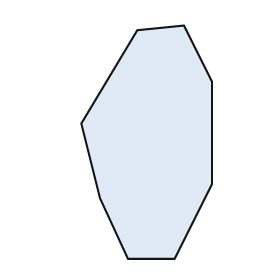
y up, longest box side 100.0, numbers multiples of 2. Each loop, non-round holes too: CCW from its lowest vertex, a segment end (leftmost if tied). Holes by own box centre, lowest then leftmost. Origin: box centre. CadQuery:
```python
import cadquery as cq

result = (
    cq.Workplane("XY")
    .moveTo(-8.0, -50.0)
    .lineTo(12.0, -50.0)
    .lineTo(28.0, -18.0)
    .lineTo(28.0, 26.0)
    .lineTo(16.0, 50.0)
    .lineTo(-4.0, 48.0)
    .lineTo(-28.0, 8.0)
    .lineTo(-20.0, -24.0)
    .close()
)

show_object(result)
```